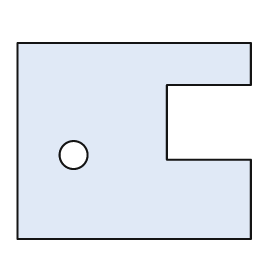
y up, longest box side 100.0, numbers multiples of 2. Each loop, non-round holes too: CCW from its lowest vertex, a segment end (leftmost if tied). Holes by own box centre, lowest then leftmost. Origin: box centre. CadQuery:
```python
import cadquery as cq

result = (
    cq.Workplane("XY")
    .moveTo(-50.0, -42.0)
    .lineTo(50.0, -42.0)
    .lineTo(50.0, -8.0)
    .lineTo(14.0, -8.0)
    .lineTo(14.0, 24.0)
    .lineTo(50.0, 24.0)
    .lineTo(50.0, 42.0)
    .lineTo(-50.0, 42.0)
    .close()
    .moveTo(-26.0, -6.0)
    .circle(6.0)
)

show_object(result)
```